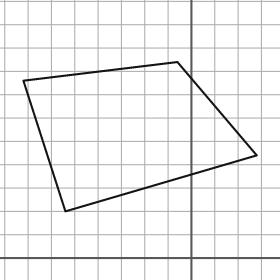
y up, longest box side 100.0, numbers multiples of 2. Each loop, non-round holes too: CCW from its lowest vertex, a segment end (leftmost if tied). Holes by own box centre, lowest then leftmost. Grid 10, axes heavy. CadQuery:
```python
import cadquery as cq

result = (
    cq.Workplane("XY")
    .moveTo(-54.0, 20.0)
    .lineTo(28.0, 44.0)
    .lineTo(-6.0, 84.0)
    .lineTo(-72.0, 76.0)
    .close()
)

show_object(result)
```